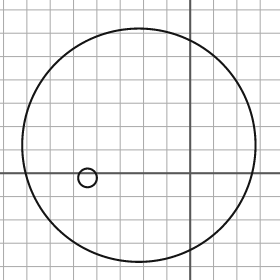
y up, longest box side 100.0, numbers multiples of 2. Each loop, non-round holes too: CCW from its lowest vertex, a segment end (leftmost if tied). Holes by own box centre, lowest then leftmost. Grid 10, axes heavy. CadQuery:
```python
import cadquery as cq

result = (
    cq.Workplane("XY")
    .moveTo(-22.0, 12.0)
    .circle(50.0)
    .moveTo(-44.0, -2.0)
    .circle(4.0)
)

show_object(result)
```